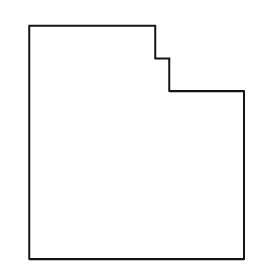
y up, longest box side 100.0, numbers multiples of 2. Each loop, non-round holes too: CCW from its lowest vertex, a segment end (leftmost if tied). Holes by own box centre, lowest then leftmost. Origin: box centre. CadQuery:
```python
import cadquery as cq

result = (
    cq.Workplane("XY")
    .moveTo(-46.0, -50.0)
    .lineTo(46.0, -50.0)
    .lineTo(46.0, 22.0)
    .lineTo(14.0, 22.0)
    .lineTo(14.0, 36.0)
    .lineTo(8.0, 36.0)
    .lineTo(8.0, 50.0)
    .lineTo(-46.0, 50.0)
    .close()
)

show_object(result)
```